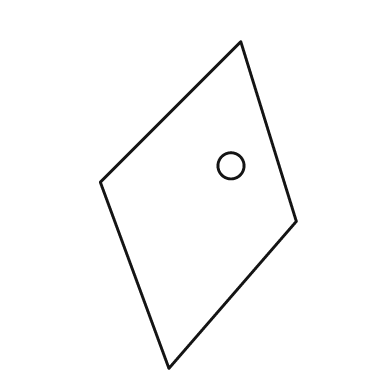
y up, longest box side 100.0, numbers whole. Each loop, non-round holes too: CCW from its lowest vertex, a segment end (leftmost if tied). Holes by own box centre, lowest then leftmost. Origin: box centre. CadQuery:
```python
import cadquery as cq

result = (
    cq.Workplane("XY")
    .moveTo(-9.0, -50.0)
    .lineTo(30.0, -5.0)
    .lineTo(13.0, 50.0)
    .lineTo(-30.0, 7.0)
    .close()
    .moveTo(10.0, 12.0)
    .circle(4.0)
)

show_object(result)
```